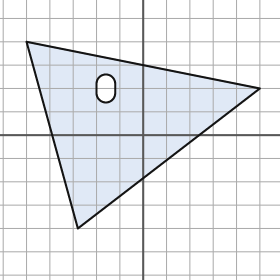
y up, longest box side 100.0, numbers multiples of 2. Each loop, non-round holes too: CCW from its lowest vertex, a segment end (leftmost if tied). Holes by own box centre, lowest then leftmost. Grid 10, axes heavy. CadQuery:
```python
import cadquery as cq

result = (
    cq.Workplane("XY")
    .moveTo(-28.0, -40.0)
    .lineTo(50.0, 20.0)
    .lineTo(-50.0, 40.0)
    .close()
    .moveTo(-20.0, 18.0)
    .threePointArc((-16.0, 14.0), (-12.0, 18.0))
    .lineTo(-12.0, 22.0)
    .threePointArc((-16.0, 26.0), (-20.0, 22.0))
    .close()
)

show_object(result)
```